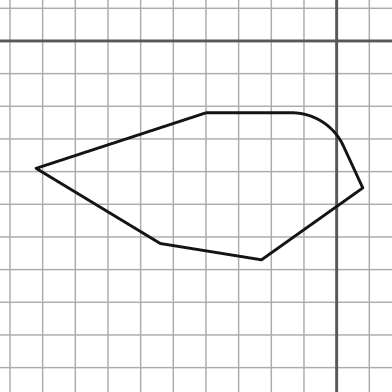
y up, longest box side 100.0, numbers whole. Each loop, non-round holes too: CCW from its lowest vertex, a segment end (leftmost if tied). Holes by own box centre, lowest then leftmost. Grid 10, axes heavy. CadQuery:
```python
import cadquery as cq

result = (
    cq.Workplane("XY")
    .moveTo(-23.0, -67.0)
    .lineTo(8.0, -45.0)
    .lineTo(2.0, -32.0)
    .threePointArc((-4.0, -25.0), (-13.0, -22.0))
    .lineTo(-40.0, -22.0)
    .lineTo(-92.0, -39.0)
    .lineTo(-54.0, -62.0)
    .close()
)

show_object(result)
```